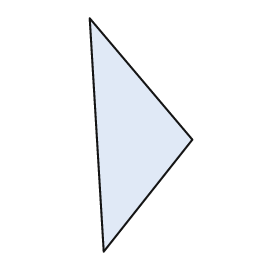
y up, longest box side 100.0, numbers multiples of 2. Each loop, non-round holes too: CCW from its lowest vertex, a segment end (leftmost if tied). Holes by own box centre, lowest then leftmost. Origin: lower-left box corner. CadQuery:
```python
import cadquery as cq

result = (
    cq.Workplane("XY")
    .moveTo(6.0, 0.0)
    .lineTo(44.0, 48.0)
    .lineTo(0.0, 100.0)
    .close()
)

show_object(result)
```